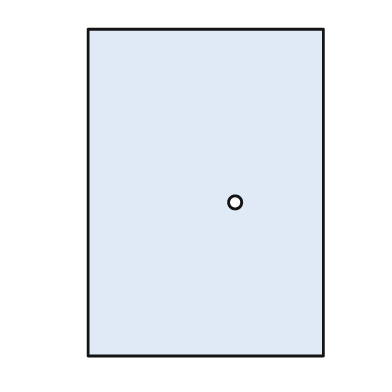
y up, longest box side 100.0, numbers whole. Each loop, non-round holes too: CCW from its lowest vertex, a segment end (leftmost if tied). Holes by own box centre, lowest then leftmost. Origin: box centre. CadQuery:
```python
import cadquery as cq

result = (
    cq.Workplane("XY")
    .moveTo(-36.0, -50.0)
    .lineTo(36.0, -50.0)
    .lineTo(36.0, 50.0)
    .lineTo(-36.0, 50.0)
    .close()
    .moveTo(9.0, -3.0)
    .circle(2.0)
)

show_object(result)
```